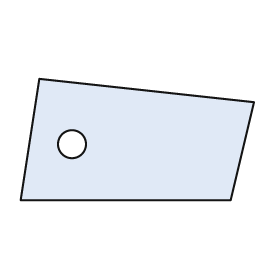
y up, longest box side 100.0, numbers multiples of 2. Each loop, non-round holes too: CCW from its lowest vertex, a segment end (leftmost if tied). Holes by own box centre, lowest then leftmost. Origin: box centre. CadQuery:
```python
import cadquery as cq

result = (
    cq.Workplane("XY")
    .moveTo(-50.0, -26.0)
    .lineTo(40.0, -26.0)
    .lineTo(50.0, 16.0)
    .lineTo(-42.0, 26.0)
    .close()
    .moveTo(-28.0, -2.0)
    .circle(6.0)
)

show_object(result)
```